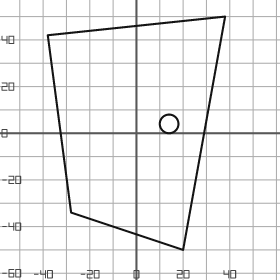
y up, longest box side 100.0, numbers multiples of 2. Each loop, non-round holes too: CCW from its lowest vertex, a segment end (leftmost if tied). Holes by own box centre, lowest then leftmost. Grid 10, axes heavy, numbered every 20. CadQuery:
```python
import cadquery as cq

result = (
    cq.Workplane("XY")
    .moveTo(20.0, -50.0)
    .lineTo(38.0, 50.0)
    .lineTo(-38.0, 42.0)
    .lineTo(-28.0, -34.0)
    .close()
    .moveTo(14.0, 4.0)
    .circle(4.0)
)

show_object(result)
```